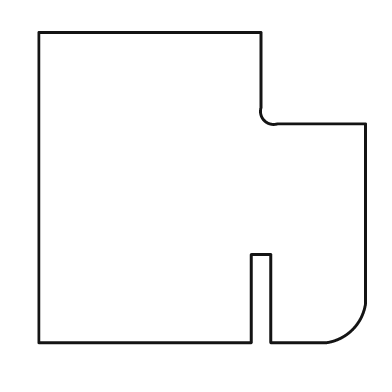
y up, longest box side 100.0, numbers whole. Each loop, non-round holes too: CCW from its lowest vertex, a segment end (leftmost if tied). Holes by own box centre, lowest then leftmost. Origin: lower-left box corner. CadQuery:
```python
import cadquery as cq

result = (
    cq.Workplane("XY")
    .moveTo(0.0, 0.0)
    .lineTo(65.0, 0.0)
    .lineTo(65.0, 27.0)
    .lineTo(71.0, 27.0)
    .lineTo(71.0, 0.0)
    .lineTo(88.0, 0.0)
    .threePointArc((96.0, 4.0), (100.0, 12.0))
    .lineTo(100.0, 67.0)
    .lineTo(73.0, 67.0)
    .threePointArc((69.0, 68.0), (68.0, 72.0))
    .lineTo(68.0, 95.0)
    .lineTo(0.0, 95.0)
    .close()
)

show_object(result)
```